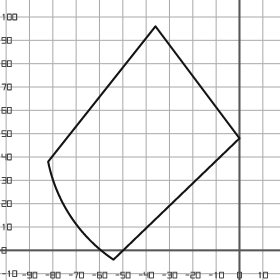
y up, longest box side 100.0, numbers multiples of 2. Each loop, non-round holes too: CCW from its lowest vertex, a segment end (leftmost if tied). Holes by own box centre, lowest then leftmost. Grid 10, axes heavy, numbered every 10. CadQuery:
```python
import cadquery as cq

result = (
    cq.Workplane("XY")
    .moveTo(-54.0, -4.0)
    .lineTo(0.0, 48.0)
    .lineTo(-36.0, 96.0)
    .lineTo(-82.0, 38.0)
    .threePointArc((-72.0, 14.0), (-54.0, -4.0))
    .close()
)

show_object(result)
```